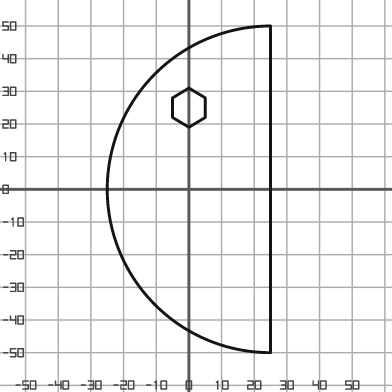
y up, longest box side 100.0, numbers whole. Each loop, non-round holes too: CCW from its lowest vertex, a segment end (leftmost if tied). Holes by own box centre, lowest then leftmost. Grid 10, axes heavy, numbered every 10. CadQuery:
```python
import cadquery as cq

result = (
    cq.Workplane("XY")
    .moveTo(25.0, -50.0)
    .lineTo(25.0, 50.0)
    .threePointArc((-25.0, 0.0), (25.0, -50.0))
    .close()
    .moveTo(0.0, 19.0)
    .lineTo(5.0, 22.0)
    .lineTo(5.0, 28.0)
    .lineTo(0.0, 31.0)
    .lineTo(-5.0, 28.0)
    .lineTo(-5.0, 22.0)
    .close()
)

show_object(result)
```